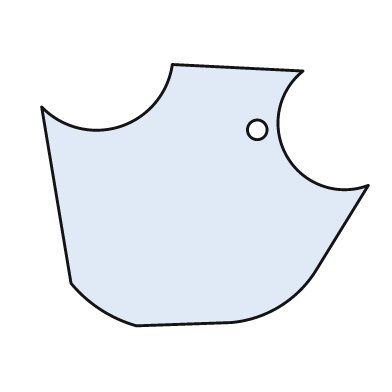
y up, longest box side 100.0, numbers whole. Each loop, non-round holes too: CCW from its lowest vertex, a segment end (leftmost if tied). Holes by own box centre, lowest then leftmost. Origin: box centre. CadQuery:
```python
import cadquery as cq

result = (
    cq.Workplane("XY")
    .moveTo(-21.0, -40.0)
    .lineTo(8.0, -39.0)
    .threePointArc((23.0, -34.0), (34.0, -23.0))
    .lineTo(50.0, 3.0)
    .threePointArc((25.0, 12.0), (30.0, 38.0))
    .lineTo(-10.0, 40.0)
    .threePointArc((-26.0, 21.0), (-50.0, 27.0))
    .lineTo(-41.0, -27.0)
    .threePointArc((-32.0, -35.0), (-21.0, -40.0))
    .close()
    .moveTo(16.0, 20.0)
    .circle(3.0)
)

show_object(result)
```